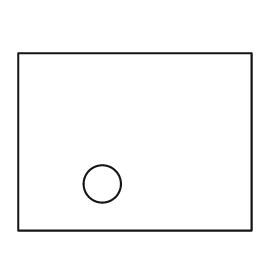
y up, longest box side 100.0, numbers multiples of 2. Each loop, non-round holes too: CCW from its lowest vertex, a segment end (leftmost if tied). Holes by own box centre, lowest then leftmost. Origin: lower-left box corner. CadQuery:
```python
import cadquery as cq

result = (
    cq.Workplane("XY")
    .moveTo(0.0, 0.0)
    .lineTo(100.0, 0.0)
    .lineTo(100.0, 76.0)
    .lineTo(0.0, 76.0)
    .close()
    .moveTo(36.0, 20.0)
    .circle(8.0)
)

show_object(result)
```